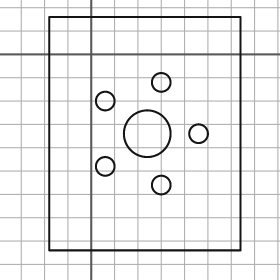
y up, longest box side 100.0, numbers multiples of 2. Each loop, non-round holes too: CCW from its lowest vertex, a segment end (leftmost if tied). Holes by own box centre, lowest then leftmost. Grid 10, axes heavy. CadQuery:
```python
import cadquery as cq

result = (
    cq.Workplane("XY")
    .moveTo(-18.0, -84.0)
    .lineTo(64.0, -84.0)
    .lineTo(64.0, 16.0)
    .lineTo(-18.0, 16.0)
    .close()
    .moveTo(30.0, -56.0)
    .circle(4.0)
    .moveTo(6.0, -48.0)
    .circle(4.0)
    .moveTo(24.0, -34.0)
    .circle(10.0)
    .moveTo(46.0, -34.0)
    .circle(4.0)
    .moveTo(6.0, -20.0)
    .circle(4.0)
    .moveTo(30.0, -12.0)
    .circle(4.0)
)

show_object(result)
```